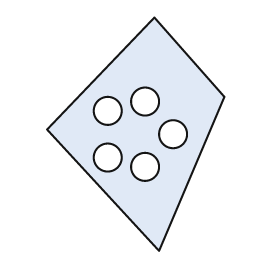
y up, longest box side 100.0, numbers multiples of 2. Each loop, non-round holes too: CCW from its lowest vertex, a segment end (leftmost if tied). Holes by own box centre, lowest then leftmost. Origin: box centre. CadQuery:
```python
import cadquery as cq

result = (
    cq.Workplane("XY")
    .moveTo(10.0, -50.0)
    .lineTo(38.0, 16.0)
    .lineTo(8.0, 50.0)
    .lineTo(-38.0, 2.0)
    .close()
    .moveTo(4.0, -14.0)
    .circle(6.0)
    .moveTo(-12.0, -10.0)
    .circle(6.0)
    .moveTo(16.0, 0.0)
    .circle(6.0)
    .moveTo(-12.0, 10.0)
    .circle(6.0)
    .moveTo(4.0, 14.0)
    .circle(6.0)
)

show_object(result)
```